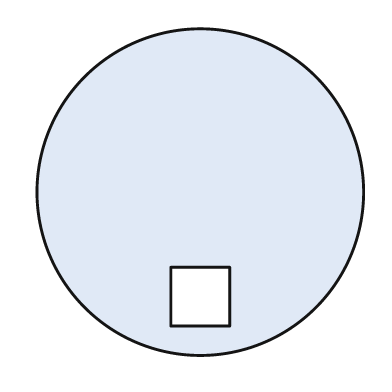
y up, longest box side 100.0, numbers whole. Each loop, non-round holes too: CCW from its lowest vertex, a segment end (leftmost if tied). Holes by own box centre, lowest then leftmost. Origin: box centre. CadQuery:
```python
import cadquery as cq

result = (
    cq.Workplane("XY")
    .moveTo(0.0, 0.0)
    .circle(50.0)
    .moveTo(-9.0, -41.0)
    .lineTo(9.0, -41.0)
    .lineTo(9.0, -23.0)
    .lineTo(-9.0, -23.0)
    .close()
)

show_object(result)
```